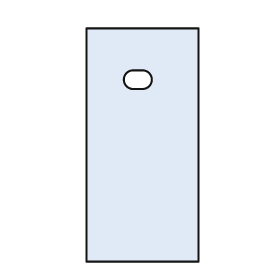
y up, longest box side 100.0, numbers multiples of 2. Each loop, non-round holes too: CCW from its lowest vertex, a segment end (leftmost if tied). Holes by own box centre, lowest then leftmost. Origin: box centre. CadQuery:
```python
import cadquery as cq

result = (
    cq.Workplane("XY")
    .moveTo(-24.0, -50.0)
    .lineTo(24.0, -50.0)
    .lineTo(24.0, 50.0)
    .lineTo(-24.0, 50.0)
    .close()
    .moveTo(-4.0, 24.0)
    .lineTo(0.0, 24.0)
    .threePointArc((4.0, 28.0), (0.0, 32.0))
    .lineTo(-4.0, 32.0)
    .threePointArc((-8.0, 28.0), (-4.0, 24.0))
    .close()
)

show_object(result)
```